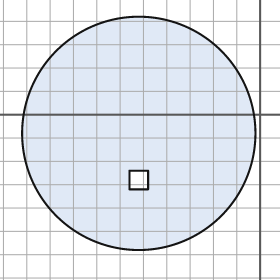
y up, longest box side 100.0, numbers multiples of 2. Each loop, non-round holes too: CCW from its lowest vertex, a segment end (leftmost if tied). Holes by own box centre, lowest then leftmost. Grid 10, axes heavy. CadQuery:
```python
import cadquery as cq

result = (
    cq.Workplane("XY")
    .moveTo(-52.0, -8.0)
    .circle(50.0)
    .moveTo(-56.0, -32.0)
    .lineTo(-48.0, -32.0)
    .lineTo(-48.0, -24.0)
    .lineTo(-56.0, -24.0)
    .close()
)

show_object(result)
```